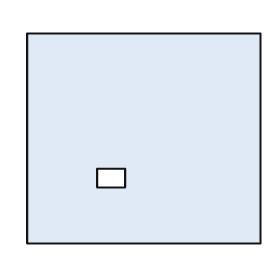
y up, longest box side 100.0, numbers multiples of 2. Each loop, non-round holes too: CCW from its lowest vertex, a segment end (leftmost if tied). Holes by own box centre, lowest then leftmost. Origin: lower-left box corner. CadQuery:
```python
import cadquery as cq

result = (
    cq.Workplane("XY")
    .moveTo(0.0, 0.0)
    .lineTo(100.0, 0.0)
    .lineTo(100.0, 90.0)
    .lineTo(0.0, 90.0)
    .close()
    .moveTo(30.0, 24.0)
    .lineTo(42.0, 24.0)
    .lineTo(42.0, 32.0)
    .lineTo(30.0, 32.0)
    .close()
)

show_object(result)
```